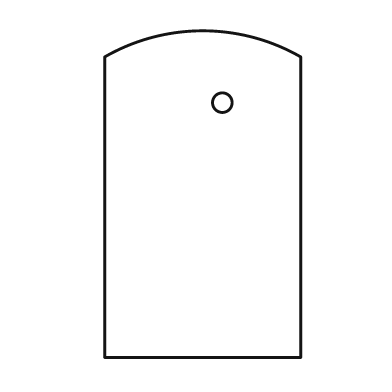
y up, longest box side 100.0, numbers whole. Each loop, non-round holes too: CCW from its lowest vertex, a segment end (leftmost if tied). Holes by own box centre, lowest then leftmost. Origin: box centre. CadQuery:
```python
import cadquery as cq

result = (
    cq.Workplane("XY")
    .moveTo(-30.0, -50.0)
    .lineTo(30.0, -50.0)
    .lineTo(30.0, 42.0)
    .threePointArc((0.0, 50.0), (-30.0, 42.0))
    .close()
    .moveTo(6.0, 28.0)
    .circle(3.0)
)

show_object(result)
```